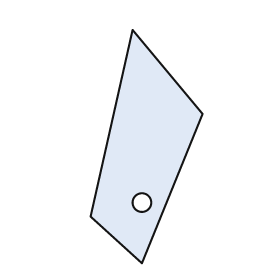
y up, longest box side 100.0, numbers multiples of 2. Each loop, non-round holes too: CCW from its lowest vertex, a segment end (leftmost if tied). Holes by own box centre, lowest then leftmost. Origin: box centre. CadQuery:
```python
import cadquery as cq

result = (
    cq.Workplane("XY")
    .moveTo(-2.0, -50.0)
    .lineTo(24.0, 14.0)
    .lineTo(-6.0, 50.0)
    .lineTo(-24.0, -30.0)
    .close()
    .moveTo(-2.0, -24.0)
    .circle(4.0)
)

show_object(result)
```